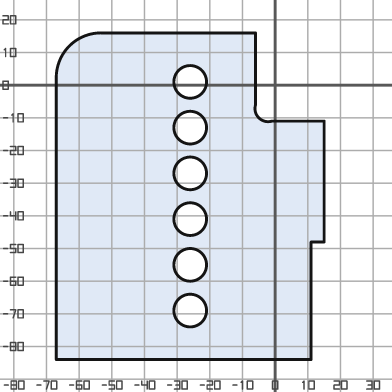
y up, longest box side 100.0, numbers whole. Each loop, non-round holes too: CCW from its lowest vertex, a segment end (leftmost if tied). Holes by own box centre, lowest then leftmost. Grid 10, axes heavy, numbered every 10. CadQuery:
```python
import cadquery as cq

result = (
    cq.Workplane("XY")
    .moveTo(-67.0, -84.0)
    .lineTo(11.0, -84.0)
    .lineTo(11.0, -48.0)
    .lineTo(15.0, -48.0)
    .lineTo(15.0, -11.0)
    .lineTo(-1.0, -11.0)
    .threePointArc((-5.0, -10.0), (-6.0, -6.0))
    .lineTo(-6.0, 16.0)
    .lineTo(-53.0, 16.0)
    .threePointArc((-63.0, 12.0), (-67.0, 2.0))
    .close()
    .moveTo(-26.0, -69.0)
    .circle(5.0)
    .moveTo(-26.0, -55.0)
    .circle(5.0)
    .moveTo(-26.0, -41.0)
    .circle(5.0)
    .moveTo(-26.0, -27.0)
    .circle(5.0)
    .moveTo(-26.0, -13.0)
    .circle(5.0)
    .moveTo(-26.0, 1.0)
    .circle(5.0)
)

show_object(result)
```